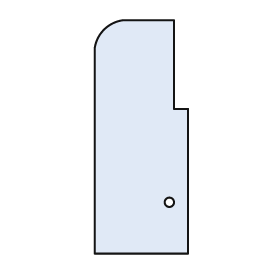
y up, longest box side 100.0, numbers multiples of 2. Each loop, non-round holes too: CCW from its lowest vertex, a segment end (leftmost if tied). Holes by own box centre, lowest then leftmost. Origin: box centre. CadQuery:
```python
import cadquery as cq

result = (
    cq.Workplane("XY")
    .moveTo(-20.0, -50.0)
    .lineTo(20.0, -50.0)
    .lineTo(20.0, 12.0)
    .lineTo(14.0, 12.0)
    .lineTo(14.0, 50.0)
    .lineTo(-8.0, 50.0)
    .threePointArc((-16.0, 46.0), (-20.0, 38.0))
    .close()
    .moveTo(12.0, -28.0)
    .circle(2.0)
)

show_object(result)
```